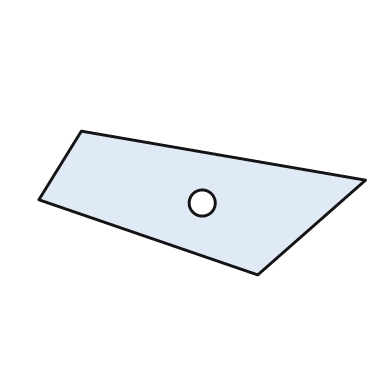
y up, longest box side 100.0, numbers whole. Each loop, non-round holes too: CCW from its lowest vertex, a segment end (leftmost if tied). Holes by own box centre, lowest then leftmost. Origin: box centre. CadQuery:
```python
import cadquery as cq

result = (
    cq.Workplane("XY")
    .moveTo(17.0, -22.0)
    .lineTo(50.0, 7.0)
    .lineTo(-37.0, 22.0)
    .lineTo(-50.0, 1.0)
    .close()
    .moveTo(0.0, 0.0)
    .circle(4.0)
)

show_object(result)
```